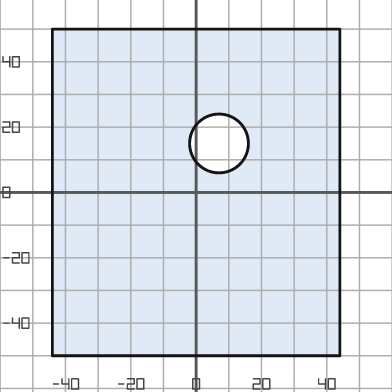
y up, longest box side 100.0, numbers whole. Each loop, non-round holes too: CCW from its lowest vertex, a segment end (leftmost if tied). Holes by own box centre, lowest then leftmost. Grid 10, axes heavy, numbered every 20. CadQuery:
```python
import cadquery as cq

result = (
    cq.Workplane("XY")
    .moveTo(-44.0, -50.0)
    .lineTo(44.0, -50.0)
    .lineTo(44.0, 50.0)
    .lineTo(-44.0, 50.0)
    .close()
    .moveTo(7.0, 15.0)
    .circle(9.0)
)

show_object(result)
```